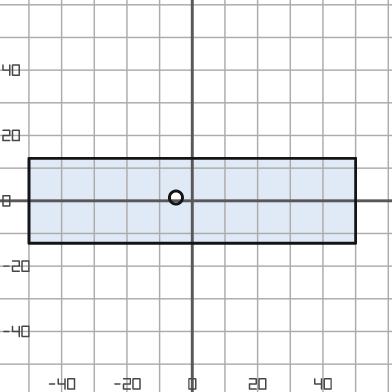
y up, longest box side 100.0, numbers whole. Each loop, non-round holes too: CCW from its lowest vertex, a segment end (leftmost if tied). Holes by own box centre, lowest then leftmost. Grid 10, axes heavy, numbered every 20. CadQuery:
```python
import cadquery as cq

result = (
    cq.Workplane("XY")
    .moveTo(-50.0, -13.0)
    .lineTo(50.0, -13.0)
    .lineTo(50.0, 13.0)
    .lineTo(-50.0, 13.0)
    .close()
    .moveTo(-5.0, 1.0)
    .circle(2.0)
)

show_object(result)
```